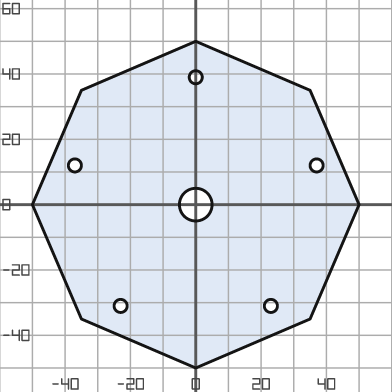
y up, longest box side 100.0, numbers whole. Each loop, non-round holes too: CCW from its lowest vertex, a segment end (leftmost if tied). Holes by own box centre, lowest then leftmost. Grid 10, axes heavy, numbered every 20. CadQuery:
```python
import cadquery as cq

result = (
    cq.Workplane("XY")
    .moveTo(0.0, -50.0)
    .lineTo(35.0, -35.0)
    .lineTo(50.0, 0.0)
    .lineTo(35.0, 35.0)
    .lineTo(0.0, 50.0)
    .lineTo(-35.0, 35.0)
    .lineTo(-50.0, 0.0)
    .lineTo(-35.0, -35.0)
    .close()
    .moveTo(-23.0, -31.0)
    .circle(2.0)
    .moveTo(23.0, -31.0)
    .circle(2.0)
    .moveTo(0.0, 0.0)
    .circle(5.0)
    .moveTo(-37.0, 12.0)
    .circle(2.0)
    .moveTo(37.0, 12.0)
    .circle(2.0)
    .moveTo(0.0, 39.0)
    .circle(2.0)
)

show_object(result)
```